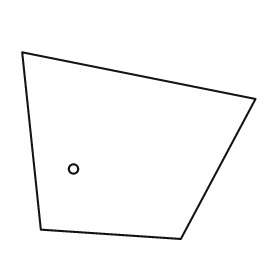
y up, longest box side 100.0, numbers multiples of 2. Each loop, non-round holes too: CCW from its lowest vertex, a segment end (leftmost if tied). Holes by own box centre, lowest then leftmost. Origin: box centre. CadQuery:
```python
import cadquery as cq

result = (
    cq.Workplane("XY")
    .moveTo(18.0, -40.0)
    .lineTo(50.0, 20.0)
    .lineTo(-50.0, 40.0)
    .lineTo(-42.0, -36.0)
    .close()
    .moveTo(-28.0, -10.0)
    .circle(2.0)
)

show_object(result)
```